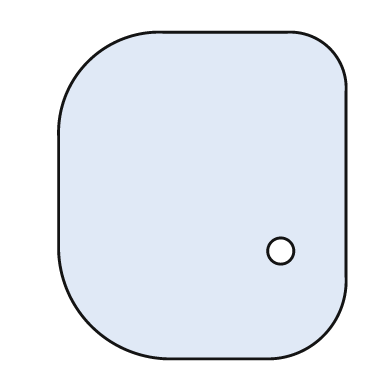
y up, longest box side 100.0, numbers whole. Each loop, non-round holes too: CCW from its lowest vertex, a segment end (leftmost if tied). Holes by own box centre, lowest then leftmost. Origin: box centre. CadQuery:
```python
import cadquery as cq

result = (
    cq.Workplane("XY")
    .moveTo(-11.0, -50.0)
    .lineTo(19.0, -50.0)
    .threePointArc((37.0, -43.0), (44.0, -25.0))
    .lineTo(44.0, 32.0)
    .threePointArc((39.0, 45.0), (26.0, 50.0))
    .lineTo(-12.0, 50.0)
    .threePointArc((-35.0, 41.0), (-44.0, 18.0))
    .lineTo(-44.0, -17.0)
    .threePointArc((-34.0, -40.0), (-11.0, -50.0))
    .close()
    .moveTo(24.0, -17.0)
    .circle(4.0)
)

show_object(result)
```